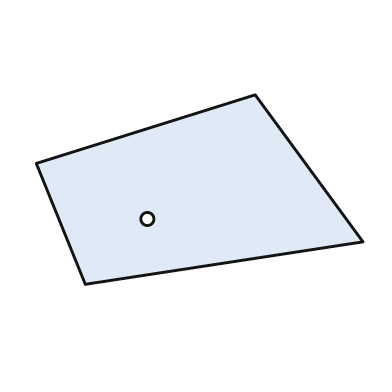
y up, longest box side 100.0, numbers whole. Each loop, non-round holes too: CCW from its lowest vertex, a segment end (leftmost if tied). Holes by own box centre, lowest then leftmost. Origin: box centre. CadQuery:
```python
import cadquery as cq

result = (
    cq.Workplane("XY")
    .moveTo(-35.0, -29.0)
    .lineTo(50.0, -16.0)
    .lineTo(17.0, 29.0)
    .lineTo(-50.0, 8.0)
    .close()
    .moveTo(-16.0, -9.0)
    .circle(2.0)
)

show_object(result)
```